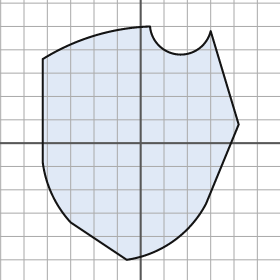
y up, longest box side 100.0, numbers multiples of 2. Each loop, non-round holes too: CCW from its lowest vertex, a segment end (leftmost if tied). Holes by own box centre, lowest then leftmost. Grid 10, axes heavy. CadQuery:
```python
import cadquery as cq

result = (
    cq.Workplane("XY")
    .moveTo(-6.0, -50.0)
    .threePointArc((14.0, -42.0), (28.0, -26.0))
    .lineTo(42.0, 8.0)
    .lineTo(30.0, 48.0)
    .threePointArc((16.0, 38.0), (4.0, 50.0))
    .threePointArc((-20.0, 46.0), (-42.0, 36.0))
    .lineTo(-42.0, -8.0)
    .threePointArc((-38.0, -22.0), (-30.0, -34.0))
    .close()
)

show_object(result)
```